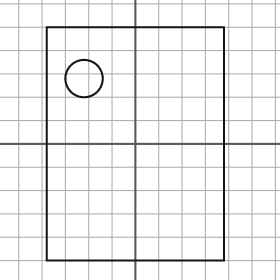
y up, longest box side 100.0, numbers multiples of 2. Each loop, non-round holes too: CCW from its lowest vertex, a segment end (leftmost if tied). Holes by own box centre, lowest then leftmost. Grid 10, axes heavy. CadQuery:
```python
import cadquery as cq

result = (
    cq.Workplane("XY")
    .moveTo(-38.0, -50.0)
    .lineTo(38.0, -50.0)
    .lineTo(38.0, 50.0)
    .lineTo(-38.0, 50.0)
    .close()
    .moveTo(-22.0, 28.0)
    .circle(8.0)
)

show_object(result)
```